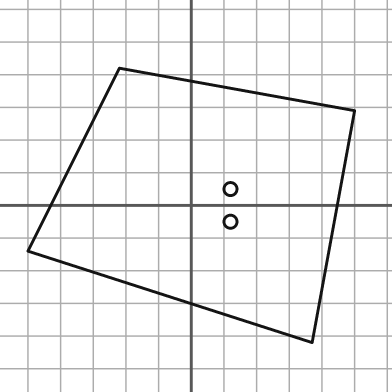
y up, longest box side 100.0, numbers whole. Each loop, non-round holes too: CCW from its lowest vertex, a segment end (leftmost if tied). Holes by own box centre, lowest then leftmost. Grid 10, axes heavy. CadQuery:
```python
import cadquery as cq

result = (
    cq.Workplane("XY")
    .moveTo(37.0, -42.0)
    .lineTo(50.0, 29.0)
    .lineTo(-22.0, 42.0)
    .lineTo(-50.0, -14.0)
    .close()
    .moveTo(12.0, -5.0)
    .circle(2.0)
    .moveTo(12.0, 5.0)
    .circle(2.0)
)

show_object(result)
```